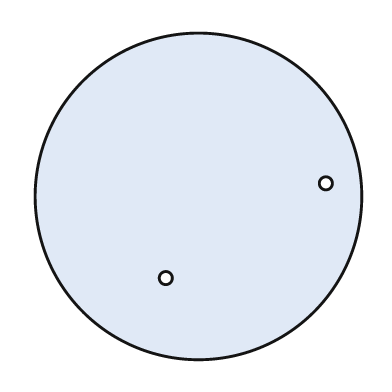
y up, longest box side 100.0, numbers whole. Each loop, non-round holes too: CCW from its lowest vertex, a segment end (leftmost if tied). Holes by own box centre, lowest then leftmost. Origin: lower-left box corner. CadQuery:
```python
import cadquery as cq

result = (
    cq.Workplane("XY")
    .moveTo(50.0, 50.0)
    .circle(50.0)
    .moveTo(40.0, 25.0)
    .circle(2.0)
    .moveTo(89.0, 54.0)
    .circle(2.0)
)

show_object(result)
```